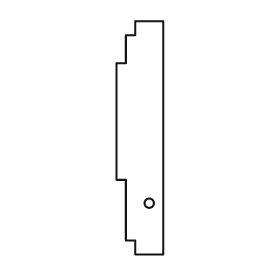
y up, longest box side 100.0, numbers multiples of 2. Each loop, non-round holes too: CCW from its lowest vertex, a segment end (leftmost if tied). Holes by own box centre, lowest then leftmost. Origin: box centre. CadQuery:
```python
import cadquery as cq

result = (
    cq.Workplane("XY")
    .moveTo(-2.0, -50.0)
    .lineTo(10.0, -50.0)
    .lineTo(10.0, 50.0)
    .lineTo(-2.0, 50.0)
    .lineTo(-2.0, 44.0)
    .lineTo(-6.0, 44.0)
    .lineTo(-6.0, 32.0)
    .lineTo(-10.0, 32.0)
    .lineTo(-10.0, -18.0)
    .lineTo(-6.0, -18.0)
    .lineTo(-6.0, -44.0)
    .lineTo(-2.0, -44.0)
    .close()
    .moveTo(4.0, -28.0)
    .circle(2.0)
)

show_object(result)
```